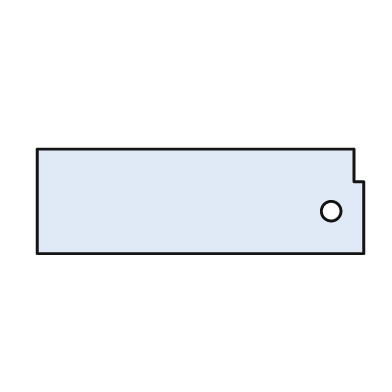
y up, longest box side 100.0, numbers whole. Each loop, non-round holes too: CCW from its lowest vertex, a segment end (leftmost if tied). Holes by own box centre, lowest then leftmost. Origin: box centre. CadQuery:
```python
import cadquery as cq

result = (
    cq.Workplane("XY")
    .moveTo(-50.0, -16.0)
    .lineTo(50.0, -16.0)
    .lineTo(50.0, 6.0)
    .lineTo(47.0, 6.0)
    .lineTo(47.0, 16.0)
    .lineTo(-50.0, 16.0)
    .close()
    .moveTo(40.0, -3.0)
    .circle(3.0)
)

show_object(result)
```